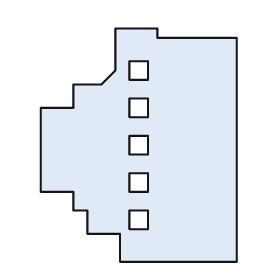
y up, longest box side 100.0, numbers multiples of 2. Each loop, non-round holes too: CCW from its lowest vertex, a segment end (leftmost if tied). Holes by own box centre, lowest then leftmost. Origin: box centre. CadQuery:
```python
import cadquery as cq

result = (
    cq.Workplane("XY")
    .moveTo(-8.0, -50.0)
    .lineTo(42.0, -50.0)
    .lineTo(42.0, 46.0)
    .lineTo(8.0, 46.0)
    .lineTo(8.0, 50.0)
    .lineTo(-10.0, 50.0)
    .lineTo(-10.0, 32.0)
    .lineTo(-16.0, 26.0)
    .lineTo(-28.0, 26.0)
    .lineTo(-28.0, 16.0)
    .lineTo(-42.0, 16.0)
    .lineTo(-42.0, -20.0)
    .lineTo(-28.0, -20.0)
    .lineTo(-28.0, -28.0)
    .lineTo(-22.0, -28.0)
    .lineTo(-22.0, -38.0)
    .lineTo(-8.0, -38.0)
    .close()
    .moveTo(-4.0, -36.0)
    .lineTo(4.0, -36.0)
    .lineTo(4.0, -28.0)
    .lineTo(-4.0, -28.0)
    .close()
    .moveTo(-4.0, -20.0)
    .lineTo(4.0, -20.0)
    .lineTo(4.0, -12.0)
    .lineTo(-4.0, -12.0)
    .close()
    .moveTo(-4.0, -4.0)
    .lineTo(4.0, -4.0)
    .lineTo(4.0, 4.0)
    .lineTo(-4.0, 4.0)
    .close()
    .moveTo(-4.0, 12.0)
    .lineTo(4.0, 12.0)
    .lineTo(4.0, 20.0)
    .lineTo(-4.0, 20.0)
    .close()
    .moveTo(-4.0, 28.0)
    .lineTo(4.0, 28.0)
    .lineTo(4.0, 36.0)
    .lineTo(-4.0, 36.0)
    .close()
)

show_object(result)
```